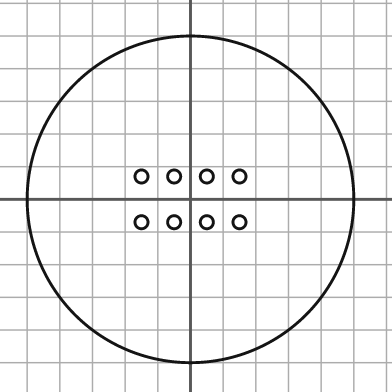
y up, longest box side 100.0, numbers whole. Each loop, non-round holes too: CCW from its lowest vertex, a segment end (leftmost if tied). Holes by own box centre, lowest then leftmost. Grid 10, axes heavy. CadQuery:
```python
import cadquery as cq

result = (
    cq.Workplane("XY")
    .moveTo(0.0, 0.0)
    .circle(50.0)
    .moveTo(-15.0, -7.0)
    .circle(2.0)
    .moveTo(-5.0, -7.0)
    .circle(2.0)
    .moveTo(5.0, -7.0)
    .circle(2.0)
    .moveTo(15.0, -7.0)
    .circle(2.0)
    .moveTo(-15.0, 7.0)
    .circle(2.0)
    .moveTo(-5.0, 7.0)
    .circle(2.0)
    .moveTo(5.0, 7.0)
    .circle(2.0)
    .moveTo(15.0, 7.0)
    .circle(2.0)
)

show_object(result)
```